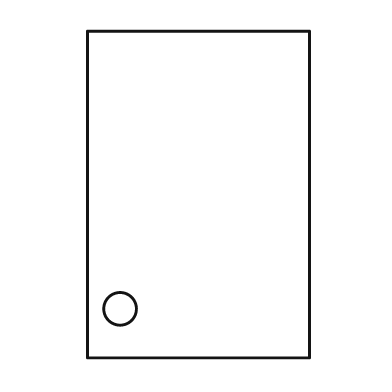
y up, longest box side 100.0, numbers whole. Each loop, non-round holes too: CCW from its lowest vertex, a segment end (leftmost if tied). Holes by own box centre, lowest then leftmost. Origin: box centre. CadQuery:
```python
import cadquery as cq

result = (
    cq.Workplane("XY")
    .moveTo(-34.0, -50.0)
    .lineTo(34.0, -50.0)
    .lineTo(34.0, 50.0)
    .lineTo(-34.0, 50.0)
    .close()
    .moveTo(-24.0, -35.0)
    .circle(5.0)
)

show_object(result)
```